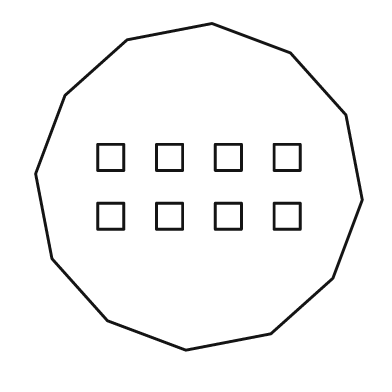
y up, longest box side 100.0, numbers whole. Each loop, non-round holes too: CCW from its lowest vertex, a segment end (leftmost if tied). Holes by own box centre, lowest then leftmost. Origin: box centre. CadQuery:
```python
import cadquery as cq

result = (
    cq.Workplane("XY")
    .moveTo(-4.0, -50.0)
    .lineTo(22.0, -45.0)
    .lineTo(41.0, -28.0)
    .lineTo(50.0, -4.0)
    .lineTo(45.0, 22.0)
    .lineTo(28.0, 41.0)
    .lineTo(4.0, 50.0)
    .lineTo(-22.0, 45.0)
    .lineTo(-41.0, 28.0)
    .lineTo(-50.0, 4.0)
    .lineTo(-45.0, -22.0)
    .lineTo(-28.0, -41.0)
    .close()
    .moveTo(-31.0, -13.0)
    .lineTo(-23.0, -13.0)
    .lineTo(-23.0, -5.0)
    .lineTo(-31.0, -5.0)
    .close()
    .moveTo(-13.0, -13.0)
    .lineTo(-5.0, -13.0)
    .lineTo(-5.0, -5.0)
    .lineTo(-13.0, -5.0)
    .close()
    .moveTo(5.0, -13.0)
    .lineTo(13.0, -13.0)
    .lineTo(13.0, -5.0)
    .lineTo(5.0, -5.0)
    .close()
    .moveTo(23.0, -13.0)
    .lineTo(31.0, -13.0)
    .lineTo(31.0, -5.0)
    .lineTo(23.0, -5.0)
    .close()
    .moveTo(-31.0, 5.0)
    .lineTo(-23.0, 5.0)
    .lineTo(-23.0, 13.0)
    .lineTo(-31.0, 13.0)
    .close()
    .moveTo(-13.0, 5.0)
    .lineTo(-5.0, 5.0)
    .lineTo(-5.0, 13.0)
    .lineTo(-13.0, 13.0)
    .close()
    .moveTo(5.0, 5.0)
    .lineTo(13.0, 5.0)
    .lineTo(13.0, 13.0)
    .lineTo(5.0, 13.0)
    .close()
    .moveTo(23.0, 5.0)
    .lineTo(31.0, 5.0)
    .lineTo(31.0, 13.0)
    .lineTo(23.0, 13.0)
    .close()
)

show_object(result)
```